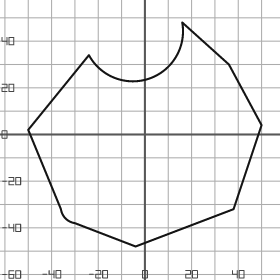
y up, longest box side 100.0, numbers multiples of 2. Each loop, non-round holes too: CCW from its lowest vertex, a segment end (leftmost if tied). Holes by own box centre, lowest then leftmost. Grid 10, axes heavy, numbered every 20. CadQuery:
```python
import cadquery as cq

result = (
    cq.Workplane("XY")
    .moveTo(-4.0, -48.0)
    .lineTo(38.0, -32.0)
    .lineTo(50.0, 4.0)
    .lineTo(36.0, 30.0)
    .lineTo(16.0, 48.0)
    .threePointArc((2.0, 24.0), (-24.0, 34.0))
    .lineTo(-50.0, 2.0)
    .lineTo(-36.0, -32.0)
    .threePointArc((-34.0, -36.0), (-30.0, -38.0))
    .close()
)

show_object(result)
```